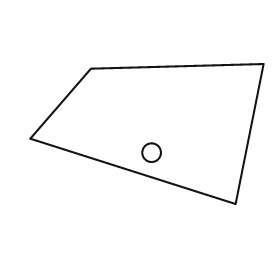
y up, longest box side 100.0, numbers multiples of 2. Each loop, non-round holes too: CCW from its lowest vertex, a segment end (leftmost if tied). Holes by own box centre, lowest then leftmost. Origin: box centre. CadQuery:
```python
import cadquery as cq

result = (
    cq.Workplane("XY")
    .moveTo(38.0, -30.0)
    .lineTo(50.0, 30.0)
    .lineTo(-24.0, 28.0)
    .lineTo(-50.0, -2.0)
    .close()
    .moveTo(2.0, -8.0)
    .circle(4.0)
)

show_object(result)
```